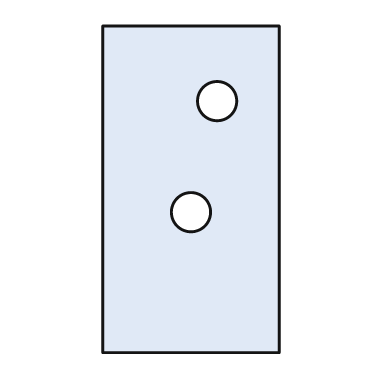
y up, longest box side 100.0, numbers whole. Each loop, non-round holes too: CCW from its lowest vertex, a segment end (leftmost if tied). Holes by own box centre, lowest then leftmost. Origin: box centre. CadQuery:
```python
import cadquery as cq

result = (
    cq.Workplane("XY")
    .moveTo(-27.0, -50.0)
    .lineTo(27.0, -50.0)
    .lineTo(27.0, 50.0)
    .lineTo(-27.0, 50.0)
    .close()
    .moveTo(0.0, -7.0)
    .circle(6.0)
    .moveTo(8.0, 27.0)
    .circle(6.0)
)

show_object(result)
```